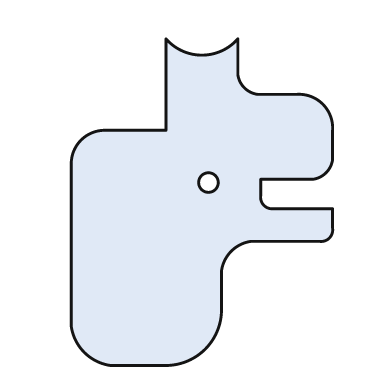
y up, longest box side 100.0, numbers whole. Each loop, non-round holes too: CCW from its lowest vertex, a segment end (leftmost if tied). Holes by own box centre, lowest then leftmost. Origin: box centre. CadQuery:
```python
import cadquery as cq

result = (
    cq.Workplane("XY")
    .moveTo(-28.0, -50.0)
    .lineTo(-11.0, -50.0)
    .threePointArc((1.0, -45.0), (6.0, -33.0))
    .lineTo(6.0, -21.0)
    .threePointArc((9.0, -15.0), (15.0, -12.0))
    .lineTo(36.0, -12.0)
    .threePointArc((39.0, -11.0), (40.0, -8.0))
    .lineTo(40.0, -2.0)
    .lineTo(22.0, -2.0)
    .threePointArc((19.0, -1.0), (18.0, 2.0))
    .lineTo(18.0, 7.0)
    .lineTo(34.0, 7.0)
    .threePointArc((38.0, 9.0), (40.0, 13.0))
    .lineTo(40.0, 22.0)
    .threePointArc((37.0, 30.0), (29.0, 33.0))
    .lineTo(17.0, 33.0)
    .threePointArc((13.0, 35.0), (11.0, 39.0))
    .lineTo(11.0, 50.0)
    .threePointArc((0.0, 45.0), (-11.0, 50.0))
    .lineTo(-11.0, 22.0)
    .lineTo(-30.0, 22.0)
    .threePointArc((-37.0, 19.0), (-40.0, 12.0))
    .lineTo(-40.0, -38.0)
    .threePointArc((-36.0, -46.0), (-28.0, -50.0))
    .close()
    .moveTo(2.0, 6.0)
    .circle(3.0)
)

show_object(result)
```